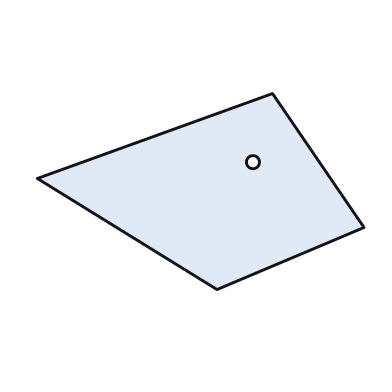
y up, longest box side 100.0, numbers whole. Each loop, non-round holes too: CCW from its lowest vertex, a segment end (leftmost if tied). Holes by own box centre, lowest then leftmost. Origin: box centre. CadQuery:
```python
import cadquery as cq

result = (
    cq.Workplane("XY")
    .moveTo(5.0, -30.0)
    .lineTo(50.0, -11.0)
    .lineTo(22.0, 30.0)
    .lineTo(-50.0, 4.0)
    .close()
    .moveTo(16.0, 9.0)
    .circle(2.0)
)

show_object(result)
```